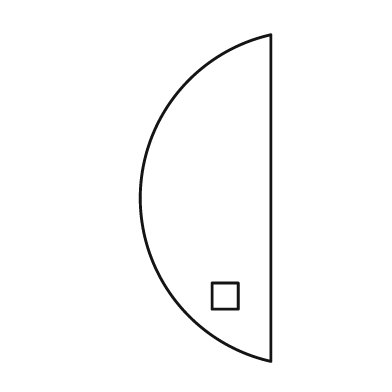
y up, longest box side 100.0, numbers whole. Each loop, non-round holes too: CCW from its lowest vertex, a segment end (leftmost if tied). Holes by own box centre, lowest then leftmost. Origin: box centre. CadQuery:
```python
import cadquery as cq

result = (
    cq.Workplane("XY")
    .moveTo(20.0, -50.0)
    .lineTo(20.0, 50.0)
    .threePointArc((-20.0, 0.0), (20.0, -50.0))
    .close()
    .moveTo(2.0, -34.0)
    .lineTo(10.0, -34.0)
    .lineTo(10.0, -26.0)
    .lineTo(2.0, -26.0)
    .close()
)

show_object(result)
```